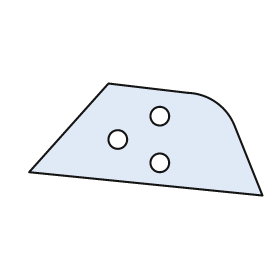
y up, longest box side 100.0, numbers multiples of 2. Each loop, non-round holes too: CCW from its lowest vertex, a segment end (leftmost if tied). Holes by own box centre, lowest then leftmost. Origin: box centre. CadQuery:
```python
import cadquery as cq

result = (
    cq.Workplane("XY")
    .moveTo(50.0, -24.0)
    .lineTo(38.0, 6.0)
    .threePointArc((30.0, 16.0), (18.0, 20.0))
    .lineTo(-16.0, 24.0)
    .lineTo(-50.0, -14.0)
    .close()
    .moveTo(6.0, -10.0)
    .circle(4.0)
    .moveTo(-12.0, 0.0)
    .circle(4.0)
    .moveTo(6.0, 10.0)
    .circle(4.0)
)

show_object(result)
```